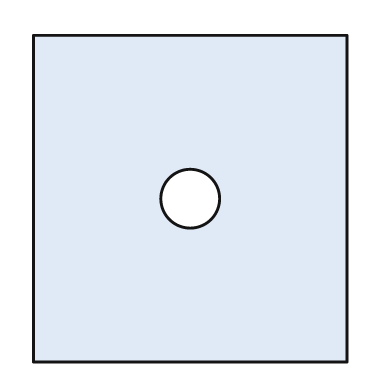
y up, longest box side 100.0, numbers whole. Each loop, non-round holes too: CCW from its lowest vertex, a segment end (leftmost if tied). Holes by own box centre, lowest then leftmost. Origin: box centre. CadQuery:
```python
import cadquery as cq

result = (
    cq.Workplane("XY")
    .moveTo(-48.0, -50.0)
    .lineTo(48.0, -50.0)
    .lineTo(48.0, 50.0)
    .lineTo(-48.0, 50.0)
    .close()
    .moveTo(0.0, 0.0)
    .circle(9.0)
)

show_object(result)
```